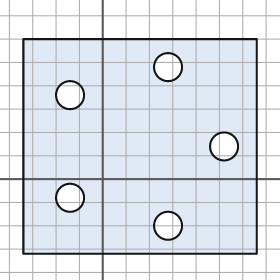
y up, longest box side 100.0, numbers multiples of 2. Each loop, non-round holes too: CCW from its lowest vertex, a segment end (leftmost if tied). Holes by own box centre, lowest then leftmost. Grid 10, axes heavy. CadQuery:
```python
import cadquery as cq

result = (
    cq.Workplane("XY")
    .moveTo(-34.0, -32.0)
    .lineTo(66.0, -32.0)
    .lineTo(66.0, 60.0)
    .lineTo(-34.0, 60.0)
    .close()
    .moveTo(28.0, -20.0)
    .circle(6.0)
    .moveTo(-14.0, -8.0)
    .circle(6.0)
    .moveTo(52.0, 14.0)
    .circle(6.0)
    .moveTo(-14.0, 36.0)
    .circle(6.0)
    .moveTo(28.0, 48.0)
    .circle(6.0)
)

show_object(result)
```